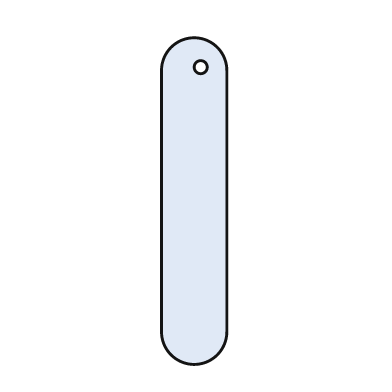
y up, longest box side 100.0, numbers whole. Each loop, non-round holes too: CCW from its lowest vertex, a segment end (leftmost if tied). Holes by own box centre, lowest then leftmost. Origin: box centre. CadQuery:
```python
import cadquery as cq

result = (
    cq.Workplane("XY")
    .moveTo(-10.0, -40.0)
    .threePointArc((0.0, -50.0), (10.0, -40.0))
    .lineTo(10.0, 40.0)
    .threePointArc((0.0, 50.0), (-10.0, 40.0))
    .close()
    .moveTo(2.0, 41.0)
    .circle(2.0)
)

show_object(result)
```